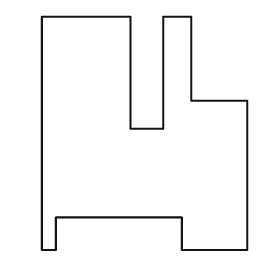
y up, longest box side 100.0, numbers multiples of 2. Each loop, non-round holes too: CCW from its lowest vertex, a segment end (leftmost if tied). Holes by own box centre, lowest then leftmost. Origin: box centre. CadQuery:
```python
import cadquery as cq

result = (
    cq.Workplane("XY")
    .moveTo(-44.0, -50.0)
    .lineTo(-38.0, -50.0)
    .lineTo(-38.0, -36.0)
    .lineTo(16.0, -36.0)
    .lineTo(16.0, -50.0)
    .lineTo(44.0, -50.0)
    .lineTo(44.0, 14.0)
    .lineTo(20.0, 14.0)
    .lineTo(20.0, 50.0)
    .lineTo(8.0, 50.0)
    .lineTo(8.0, 2.0)
    .lineTo(-6.0, 2.0)
    .lineTo(-6.0, 50.0)
    .lineTo(-44.0, 50.0)
    .close()
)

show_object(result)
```